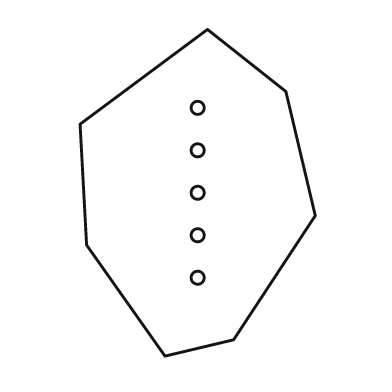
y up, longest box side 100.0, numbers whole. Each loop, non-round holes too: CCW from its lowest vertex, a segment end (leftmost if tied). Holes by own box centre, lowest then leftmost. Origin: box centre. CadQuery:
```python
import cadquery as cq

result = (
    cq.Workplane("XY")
    .moveTo(-10.0, -50.0)
    .lineTo(11.0, -45.0)
    .lineTo(36.0, -7.0)
    .lineTo(27.0, 31.0)
    .lineTo(3.0, 50.0)
    .lineTo(-36.0, 21.0)
    .lineTo(-34.0, -16.0)
    .close()
    .moveTo(0.0, -26.0)
    .circle(2.0)
    .moveTo(0.0, -13.0)
    .circle(2.0)
    .moveTo(0.0, 0.0)
    .circle(2.0)
    .moveTo(0.0, 13.0)
    .circle(2.0)
    .moveTo(0.0, 26.0)
    .circle(2.0)
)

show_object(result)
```